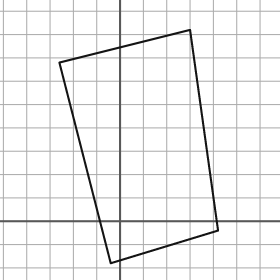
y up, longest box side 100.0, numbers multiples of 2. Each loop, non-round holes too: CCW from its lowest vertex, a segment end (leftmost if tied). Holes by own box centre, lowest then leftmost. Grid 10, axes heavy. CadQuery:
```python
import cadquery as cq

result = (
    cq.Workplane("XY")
    .moveTo(-4.0, -18.0)
    .lineTo(42.0, -4.0)
    .lineTo(30.0, 82.0)
    .lineTo(-26.0, 68.0)
    .close()
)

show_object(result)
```